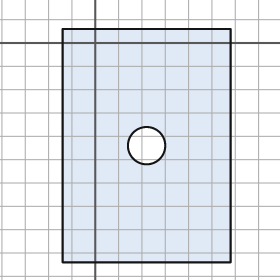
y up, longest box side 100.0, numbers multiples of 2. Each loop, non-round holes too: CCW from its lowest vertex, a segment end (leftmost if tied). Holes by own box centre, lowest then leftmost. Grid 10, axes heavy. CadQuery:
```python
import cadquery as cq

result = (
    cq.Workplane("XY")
    .moveTo(-14.0, -94.0)
    .lineTo(58.0, -94.0)
    .lineTo(58.0, 6.0)
    .lineTo(-14.0, 6.0)
    .close()
    .moveTo(22.0, -44.0)
    .circle(8.0)
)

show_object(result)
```